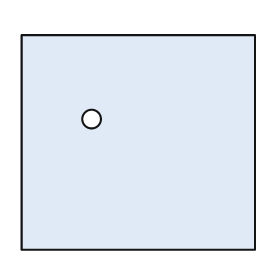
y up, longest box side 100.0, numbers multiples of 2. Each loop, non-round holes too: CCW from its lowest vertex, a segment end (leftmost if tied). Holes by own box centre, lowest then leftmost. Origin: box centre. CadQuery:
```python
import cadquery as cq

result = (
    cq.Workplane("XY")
    .moveTo(-50.0, -46.0)
    .lineTo(50.0, -46.0)
    .lineTo(50.0, 46.0)
    .lineTo(-50.0, 46.0)
    .close()
    .moveTo(-20.0, 10.0)
    .circle(4.0)
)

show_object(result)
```